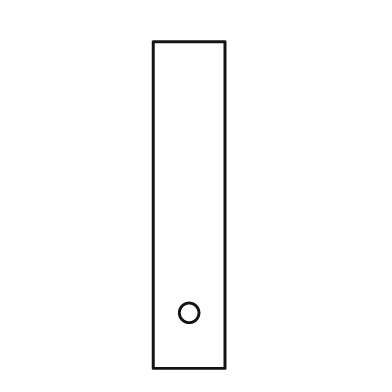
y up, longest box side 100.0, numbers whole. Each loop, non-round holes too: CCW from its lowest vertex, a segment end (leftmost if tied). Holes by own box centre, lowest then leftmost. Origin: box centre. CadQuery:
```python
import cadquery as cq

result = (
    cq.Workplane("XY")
    .moveTo(-11.0, -50.0)
    .lineTo(11.0, -50.0)
    .lineTo(11.0, 50.0)
    .lineTo(-11.0, 50.0)
    .close()
    .moveTo(0.0, -33.0)
    .circle(3.0)
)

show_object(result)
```